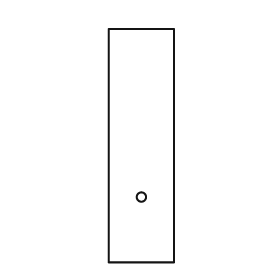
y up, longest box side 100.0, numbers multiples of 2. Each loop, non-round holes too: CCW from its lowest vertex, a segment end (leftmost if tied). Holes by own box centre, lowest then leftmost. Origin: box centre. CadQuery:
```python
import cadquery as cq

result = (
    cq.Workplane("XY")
    .moveTo(-14.0, -50.0)
    .lineTo(14.0, -50.0)
    .lineTo(14.0, 50.0)
    .lineTo(-14.0, 50.0)
    .close()
    .moveTo(0.0, -22.0)
    .circle(2.0)
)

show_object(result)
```